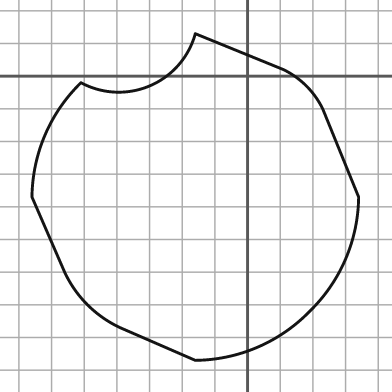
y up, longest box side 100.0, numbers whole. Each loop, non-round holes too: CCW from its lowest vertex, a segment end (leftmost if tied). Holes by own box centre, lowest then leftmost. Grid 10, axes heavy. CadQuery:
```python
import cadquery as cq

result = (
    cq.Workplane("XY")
    .moveTo(-16.0, -87.0)
    .threePointArc((3.0, -83.0), (19.0, -72.0))
    .threePointArc((30.0, -56.0), (34.0, -37.0))
    .lineTo(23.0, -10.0)
    .threePointArc((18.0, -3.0), (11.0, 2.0))
    .lineTo(-16.0, 13.0)
    .threePointArc((-30.0, -3.0), (-51.0, -2.0))
    .threePointArc((-62.0, -18.0), (-66.0, -37.0))
    .lineTo(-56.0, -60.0)
    .threePointArc((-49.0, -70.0), (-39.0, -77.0))
    .close()
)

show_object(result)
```